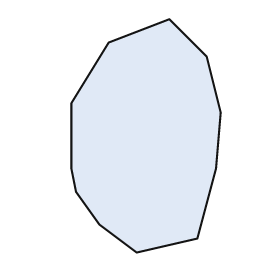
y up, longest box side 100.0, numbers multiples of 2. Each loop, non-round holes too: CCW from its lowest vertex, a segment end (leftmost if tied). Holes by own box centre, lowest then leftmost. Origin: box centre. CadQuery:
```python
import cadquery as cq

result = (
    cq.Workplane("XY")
    .moveTo(-4.0, -50.0)
    .lineTo(22.0, -44.0)
    .lineTo(30.0, -14.0)
    .lineTo(32.0, 10.0)
    .lineTo(26.0, 34.0)
    .lineTo(10.0, 50.0)
    .lineTo(-16.0, 40.0)
    .lineTo(-32.0, 14.0)
    .lineTo(-32.0, -14.0)
    .lineTo(-30.0, -24.0)
    .lineTo(-20.0, -38.0)
    .close()
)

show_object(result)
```